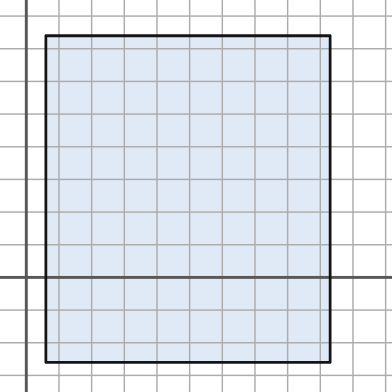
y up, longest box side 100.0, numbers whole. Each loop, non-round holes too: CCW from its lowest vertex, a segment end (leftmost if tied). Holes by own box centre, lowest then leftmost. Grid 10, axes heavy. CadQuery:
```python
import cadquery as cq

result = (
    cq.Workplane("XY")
    .moveTo(6.0, -26.0)
    .lineTo(93.0, -26.0)
    .lineTo(93.0, 74.0)
    .lineTo(6.0, 74.0)
    .close()
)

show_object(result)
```